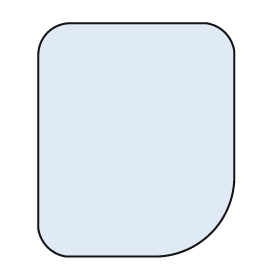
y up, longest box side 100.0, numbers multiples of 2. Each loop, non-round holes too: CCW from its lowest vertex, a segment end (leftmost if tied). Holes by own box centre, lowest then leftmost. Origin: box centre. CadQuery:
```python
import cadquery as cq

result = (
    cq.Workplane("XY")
    .moveTo(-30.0, -50.0)
    .lineTo(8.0, -50.0)
    .threePointArc((32.0, -40.0), (42.0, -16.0))
    .lineTo(42.0, 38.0)
    .threePointArc((38.0, 46.0), (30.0, 50.0))
    .lineTo(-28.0, 50.0)
    .threePointArc((-38.0, 46.0), (-42.0, 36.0))
    .lineTo(-42.0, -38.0)
    .threePointArc((-38.0, -46.0), (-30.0, -50.0))
    .close()
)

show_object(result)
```